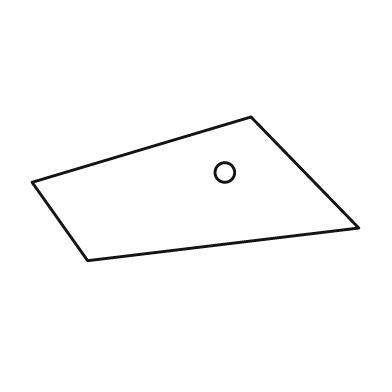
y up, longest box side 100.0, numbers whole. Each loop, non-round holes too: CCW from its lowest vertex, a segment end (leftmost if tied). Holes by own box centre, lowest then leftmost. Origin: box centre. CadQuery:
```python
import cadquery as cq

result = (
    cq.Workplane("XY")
    .moveTo(-33.0, -22.0)
    .lineTo(50.0, -12.0)
    .lineTo(17.0, 22.0)
    .lineTo(-50.0, 2.0)
    .close()
    .moveTo(9.0, 5.0)
    .circle(3.0)
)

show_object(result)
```